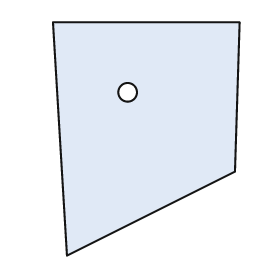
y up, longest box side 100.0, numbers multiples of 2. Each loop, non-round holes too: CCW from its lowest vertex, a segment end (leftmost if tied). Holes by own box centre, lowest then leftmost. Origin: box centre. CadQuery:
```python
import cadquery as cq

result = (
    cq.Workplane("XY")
    .moveTo(-34.0, -50.0)
    .lineTo(38.0, -14.0)
    .lineTo(40.0, 50.0)
    .lineTo(-40.0, 50.0)
    .close()
    .moveTo(-8.0, 20.0)
    .circle(4.0)
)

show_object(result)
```